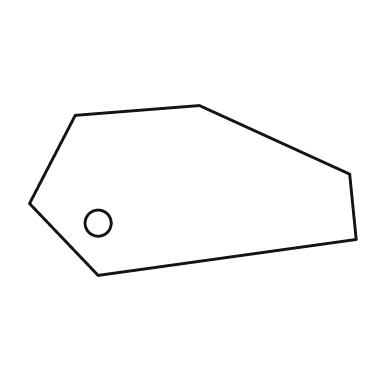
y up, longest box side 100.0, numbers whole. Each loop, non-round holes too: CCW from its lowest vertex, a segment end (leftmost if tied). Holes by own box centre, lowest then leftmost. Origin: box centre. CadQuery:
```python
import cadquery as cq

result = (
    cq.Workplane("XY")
    .moveTo(-29.0, -26.0)
    .lineTo(50.0, -15.0)
    .lineTo(48.0, 5.0)
    .lineTo(2.0, 26.0)
    .lineTo(-36.0, 23.0)
    .lineTo(-50.0, -4.0)
    .close()
    .moveTo(-29.0, -10.0)
    .circle(4.0)
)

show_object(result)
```